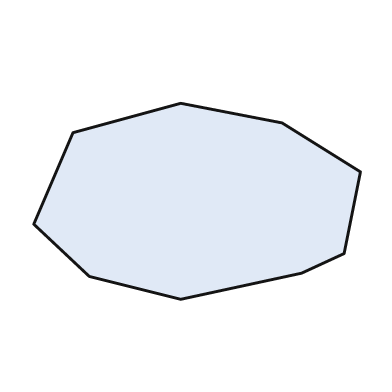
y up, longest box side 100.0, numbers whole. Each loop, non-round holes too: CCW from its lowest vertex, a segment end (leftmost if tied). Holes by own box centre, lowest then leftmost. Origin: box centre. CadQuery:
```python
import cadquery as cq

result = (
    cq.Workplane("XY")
    .moveTo(-5.0, -30.0)
    .lineTo(32.0, -22.0)
    .lineTo(45.0, -16.0)
    .lineTo(50.0, 9.0)
    .lineTo(26.0, 24.0)
    .lineTo(-5.0, 30.0)
    .lineTo(-38.0, 21.0)
    .lineTo(-50.0, -7.0)
    .lineTo(-33.0, -23.0)
    .close()
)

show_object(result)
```